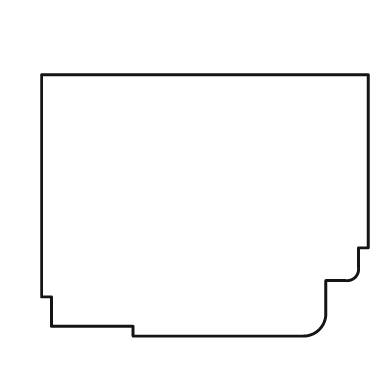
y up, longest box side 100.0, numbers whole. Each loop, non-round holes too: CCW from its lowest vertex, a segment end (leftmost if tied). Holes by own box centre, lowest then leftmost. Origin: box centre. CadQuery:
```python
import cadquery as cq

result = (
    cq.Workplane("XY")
    .moveTo(-22.0, -40.0)
    .lineTo(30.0, -40.0)
    .threePointArc((35.0, -38.0), (37.0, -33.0))
    .lineTo(37.0, -23.0)
    .lineTo(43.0, -23.0)
    .threePointArc((46.0, -22.0), (47.0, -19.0))
    .lineTo(47.0, -13.0)
    .lineTo(50.0, -13.0)
    .lineTo(50.0, 40.0)
    .lineTo(-50.0, 40.0)
    .lineTo(-50.0, -28.0)
    .lineTo(-47.0, -28.0)
    .lineTo(-47.0, -37.0)
    .lineTo(-22.0, -37.0)
    .close()
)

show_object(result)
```